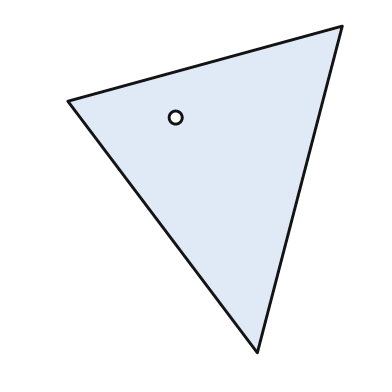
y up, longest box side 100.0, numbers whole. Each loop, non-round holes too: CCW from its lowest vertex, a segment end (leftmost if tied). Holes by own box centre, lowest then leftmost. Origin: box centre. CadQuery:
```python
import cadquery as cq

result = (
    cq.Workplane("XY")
    .moveTo(16.0, -50.0)
    .lineTo(42.0, 50.0)
    .lineTo(-42.0, 27.0)
    .close()
    .moveTo(-9.0, 22.0)
    .circle(2.0)
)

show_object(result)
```